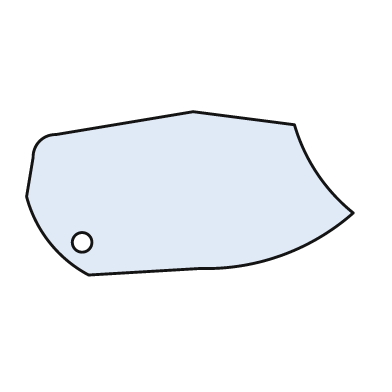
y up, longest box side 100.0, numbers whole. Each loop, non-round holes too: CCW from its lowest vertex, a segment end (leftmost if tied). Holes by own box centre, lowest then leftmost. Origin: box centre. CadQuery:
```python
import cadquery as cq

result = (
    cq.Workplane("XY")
    .moveTo(-31.0, -25.0)
    .lineTo(3.0, -23.0)
    .threePointArc((28.0, -19.0), (50.0, -6.0))
    .threePointArc((39.0, 6.0), (32.0, 21.0))
    .lineTo(1.0, 25.0)
    .lineTo(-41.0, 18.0)
    .threePointArc((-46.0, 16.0), (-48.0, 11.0))
    .lineTo(-50.0, -1.0)
    .threePointArc((-43.0, -15.0), (-31.0, -25.0))
    .close()
    .moveTo(-33.0, -15.0)
    .circle(3.0)
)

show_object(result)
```